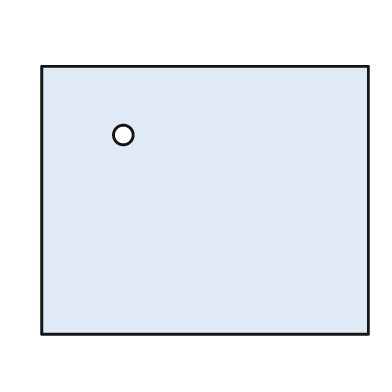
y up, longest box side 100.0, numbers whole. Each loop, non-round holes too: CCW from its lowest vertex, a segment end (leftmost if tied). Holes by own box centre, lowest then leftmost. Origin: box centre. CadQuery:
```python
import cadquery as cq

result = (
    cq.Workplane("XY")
    .moveTo(-50.0, -41.0)
    .lineTo(50.0, -41.0)
    .lineTo(50.0, 41.0)
    .lineTo(-50.0, 41.0)
    .close()
    .moveTo(-25.0, 20.0)
    .circle(3.0)
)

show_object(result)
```